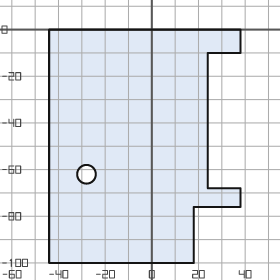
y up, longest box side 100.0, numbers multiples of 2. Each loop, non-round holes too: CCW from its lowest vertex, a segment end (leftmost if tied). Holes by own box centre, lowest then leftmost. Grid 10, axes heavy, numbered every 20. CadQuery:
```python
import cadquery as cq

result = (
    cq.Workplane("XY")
    .moveTo(-44.0, -100.0)
    .lineTo(18.0, -100.0)
    .lineTo(18.0, -76.0)
    .lineTo(38.0, -76.0)
    .lineTo(38.0, -68.0)
    .lineTo(24.0, -68.0)
    .lineTo(24.0, -10.0)
    .lineTo(38.0, -10.0)
    .lineTo(38.0, 0.0)
    .lineTo(-44.0, 0.0)
    .close()
    .moveTo(-28.0, -62.0)
    .circle(4.0)
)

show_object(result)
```